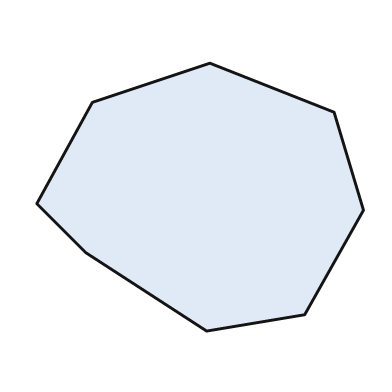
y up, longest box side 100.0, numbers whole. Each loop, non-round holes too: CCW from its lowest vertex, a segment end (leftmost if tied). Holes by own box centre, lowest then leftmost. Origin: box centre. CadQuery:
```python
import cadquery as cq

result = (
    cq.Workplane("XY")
    .moveTo(2.0, -41.0)
    .lineTo(32.0, -36.0)
    .lineTo(50.0, -4.0)
    .lineTo(41.0, 26.0)
    .lineTo(3.0, 41.0)
    .lineTo(-33.0, 29.0)
    .lineTo(-50.0, -2.0)
    .lineTo(-35.0, -17.0)
    .close()
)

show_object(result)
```